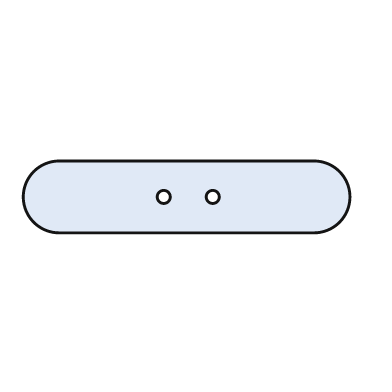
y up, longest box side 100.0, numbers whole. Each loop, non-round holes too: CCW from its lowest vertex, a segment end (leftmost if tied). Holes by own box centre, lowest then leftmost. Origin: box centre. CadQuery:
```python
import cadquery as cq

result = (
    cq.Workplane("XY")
    .moveTo(-39.0, -11.0)
    .lineTo(39.0, -11.0)
    .threePointArc((50.0, 0.0), (39.0, 11.0))
    .lineTo(-39.0, 11.0)
    .threePointArc((-50.0, 0.0), (-39.0, -11.0))
    .close()
    .moveTo(-7.0, 0.0)
    .circle(2.0)
    .moveTo(8.0, 0.0)
    .circle(2.0)
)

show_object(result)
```